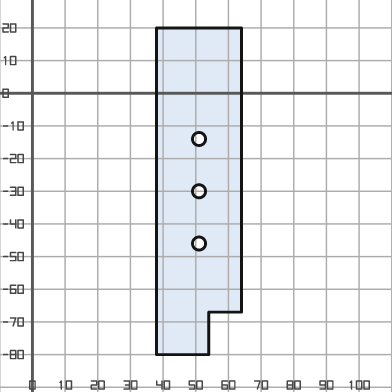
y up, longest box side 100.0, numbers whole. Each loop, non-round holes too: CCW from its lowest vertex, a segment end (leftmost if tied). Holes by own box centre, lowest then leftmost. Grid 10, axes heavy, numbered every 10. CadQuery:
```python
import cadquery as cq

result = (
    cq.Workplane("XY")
    .moveTo(38.0, -80.0)
    .lineTo(54.0, -80.0)
    .lineTo(54.0, -67.0)
    .lineTo(64.0, -67.0)
    .lineTo(64.0, 20.0)
    .lineTo(38.0, 20.0)
    .close()
    .moveTo(51.0, -46.0)
    .circle(2.0)
    .moveTo(51.0, -30.0)
    .circle(2.0)
    .moveTo(51.0, -14.0)
    .circle(2.0)
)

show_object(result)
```